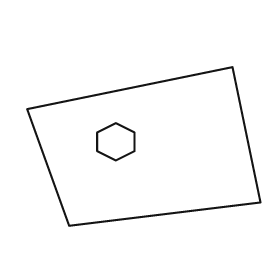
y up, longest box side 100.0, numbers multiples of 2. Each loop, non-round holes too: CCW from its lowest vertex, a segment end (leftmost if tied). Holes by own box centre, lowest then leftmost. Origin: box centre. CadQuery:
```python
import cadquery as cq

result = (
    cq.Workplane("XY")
    .moveTo(-32.0, -34.0)
    .lineTo(50.0, -24.0)
    .lineTo(38.0, 34.0)
    .lineTo(-50.0, 16.0)
    .close()
    .moveTo(-12.0, -6.0)
    .lineTo(-4.0, -2.0)
    .lineTo(-4.0, 6.0)
    .lineTo(-12.0, 10.0)
    .lineTo(-20.0, 6.0)
    .lineTo(-20.0, -2.0)
    .close()
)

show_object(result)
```